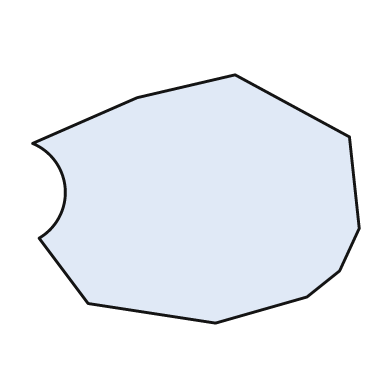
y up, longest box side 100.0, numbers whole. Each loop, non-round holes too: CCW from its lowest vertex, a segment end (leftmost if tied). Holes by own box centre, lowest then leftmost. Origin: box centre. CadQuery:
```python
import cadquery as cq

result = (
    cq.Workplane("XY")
    .moveTo(6.0, -38.0)
    .lineTo(34.0, -30.0)
    .lineTo(44.0, -22.0)
    .lineTo(50.0, -9.0)
    .lineTo(47.0, 19.0)
    .lineTo(12.0, 38.0)
    .lineTo(-18.0, 31.0)
    .lineTo(-50.0, 17.0)
    .threePointArc((-40.0, 3.0), (-48.0, -12.0))
    .lineTo(-33.0, -32.0)
    .close()
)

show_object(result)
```